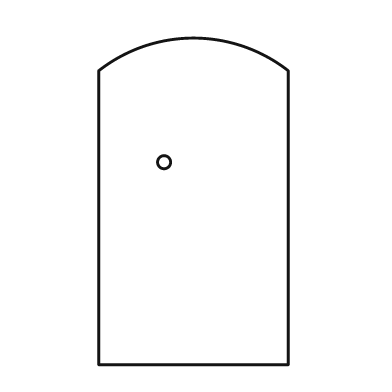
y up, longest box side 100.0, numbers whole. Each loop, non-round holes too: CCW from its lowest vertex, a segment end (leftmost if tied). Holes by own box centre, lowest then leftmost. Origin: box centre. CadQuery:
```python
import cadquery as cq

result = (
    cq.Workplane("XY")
    .moveTo(-29.0, -50.0)
    .lineTo(29.0, -50.0)
    .lineTo(29.0, 40.0)
    .threePointArc((0.0, 50.0), (-29.0, 40.0))
    .close()
    .moveTo(-9.0, 12.0)
    .circle(2.0)
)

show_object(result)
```